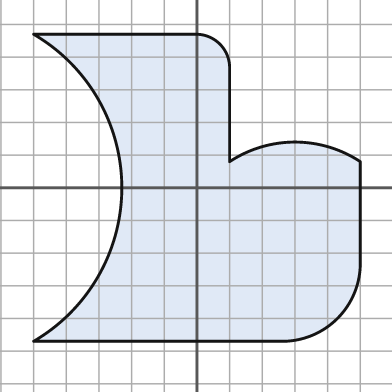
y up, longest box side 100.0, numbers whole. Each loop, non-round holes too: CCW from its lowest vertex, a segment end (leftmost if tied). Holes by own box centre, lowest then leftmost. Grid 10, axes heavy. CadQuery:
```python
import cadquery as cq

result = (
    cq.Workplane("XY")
    .moveTo(-50.0, -47.0)
    .lineTo(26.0, -47.0)
    .threePointArc((43.0, -40.0), (50.0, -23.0))
    .lineTo(50.0, 8.0)
    .threePointArc((30.0, 14.0), (10.0, 8.0))
    .lineTo(10.0, 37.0)
    .threePointArc((7.0, 44.0), (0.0, 47.0))
    .lineTo(-50.0, 47.0)
    .threePointArc((-23.0, 0.0), (-50.0, -47.0))
    .close()
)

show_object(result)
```